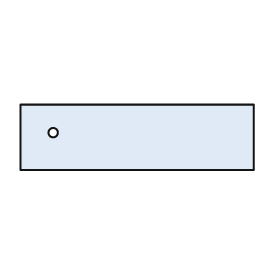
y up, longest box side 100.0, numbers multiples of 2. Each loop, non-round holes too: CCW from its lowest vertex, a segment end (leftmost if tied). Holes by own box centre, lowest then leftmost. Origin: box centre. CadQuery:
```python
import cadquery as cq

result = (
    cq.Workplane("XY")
    .moveTo(-50.0, -14.0)
    .lineTo(50.0, -14.0)
    .lineTo(50.0, 14.0)
    .lineTo(-50.0, 14.0)
    .close()
    .moveTo(-36.0, 2.0)
    .circle(2.0)
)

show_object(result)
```